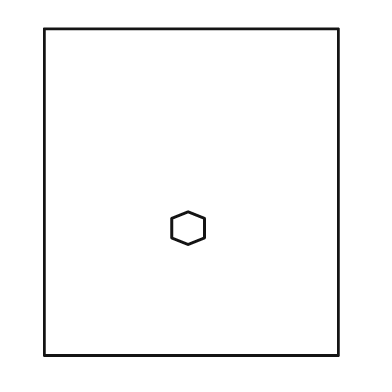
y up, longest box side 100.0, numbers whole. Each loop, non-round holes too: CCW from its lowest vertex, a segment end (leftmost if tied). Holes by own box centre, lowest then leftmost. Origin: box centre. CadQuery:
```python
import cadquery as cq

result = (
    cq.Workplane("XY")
    .moveTo(-45.0, -50.0)
    .lineTo(45.0, -50.0)
    .lineTo(45.0, 50.0)
    .lineTo(-45.0, 50.0)
    .close()
    .moveTo(-1.0, -16.0)
    .lineTo(4.0, -14.0)
    .lineTo(4.0, -8.0)
    .lineTo(-1.0, -6.0)
    .lineTo(-6.0, -8.0)
    .lineTo(-6.0, -14.0)
    .close()
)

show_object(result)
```